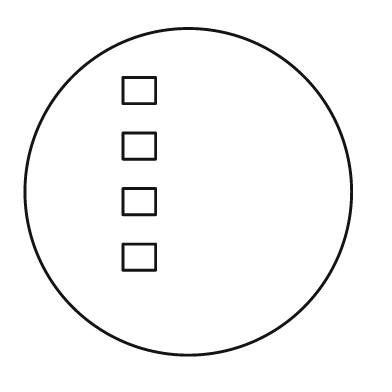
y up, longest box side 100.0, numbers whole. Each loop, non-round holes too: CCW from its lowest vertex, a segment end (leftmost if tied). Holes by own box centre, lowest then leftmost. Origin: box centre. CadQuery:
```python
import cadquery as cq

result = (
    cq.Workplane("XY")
    .moveTo(0.0, 0.0)
    .circle(50.0)
    .moveTo(-20.0, -24.0)
    .lineTo(-10.0, -24.0)
    .lineTo(-10.0, -16.0)
    .lineTo(-20.0, -16.0)
    .close()
    .moveTo(-20.0, -7.0)
    .lineTo(-10.0, -7.0)
    .lineTo(-10.0, 1.0)
    .lineTo(-20.0, 1.0)
    .close()
    .moveTo(-20.0, 10.0)
    .lineTo(-10.0, 10.0)
    .lineTo(-10.0, 18.0)
    .lineTo(-20.0, 18.0)
    .close()
    .moveTo(-20.0, 27.0)
    .lineTo(-10.0, 27.0)
    .lineTo(-10.0, 35.0)
    .lineTo(-20.0, 35.0)
    .close()
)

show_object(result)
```